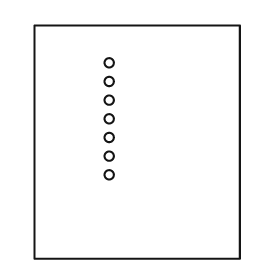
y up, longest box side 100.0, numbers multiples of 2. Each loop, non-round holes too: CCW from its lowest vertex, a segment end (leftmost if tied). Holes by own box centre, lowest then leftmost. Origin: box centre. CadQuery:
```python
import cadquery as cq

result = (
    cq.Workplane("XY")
    .moveTo(-44.0, -50.0)
    .lineTo(44.0, -50.0)
    .lineTo(44.0, 50.0)
    .lineTo(-44.0, 50.0)
    .close()
    .moveTo(-12.0, -14.0)
    .circle(2.0)
    .moveTo(-12.0, -6.0)
    .circle(2.0)
    .moveTo(-12.0, 2.0)
    .circle(2.0)
    .moveTo(-12.0, 10.0)
    .circle(2.0)
    .moveTo(-12.0, 18.0)
    .circle(2.0)
    .moveTo(-12.0, 26.0)
    .circle(2.0)
    .moveTo(-12.0, 34.0)
    .circle(2.0)
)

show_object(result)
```